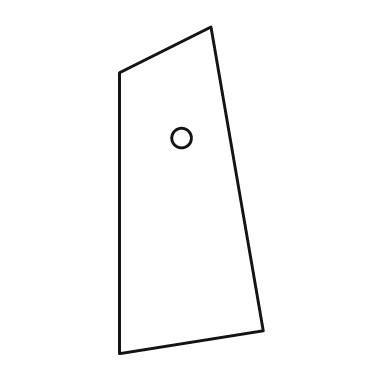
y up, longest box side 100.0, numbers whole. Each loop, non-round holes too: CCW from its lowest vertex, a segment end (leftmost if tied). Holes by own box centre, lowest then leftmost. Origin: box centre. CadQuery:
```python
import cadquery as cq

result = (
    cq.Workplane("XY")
    .moveTo(-22.0, -50.0)
    .lineTo(22.0, -43.0)
    .lineTo(6.0, 50.0)
    .lineTo(-22.0, 36.0)
    .close()
    .moveTo(-3.0, 16.0)
    .circle(3.0)
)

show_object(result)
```